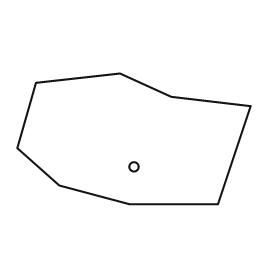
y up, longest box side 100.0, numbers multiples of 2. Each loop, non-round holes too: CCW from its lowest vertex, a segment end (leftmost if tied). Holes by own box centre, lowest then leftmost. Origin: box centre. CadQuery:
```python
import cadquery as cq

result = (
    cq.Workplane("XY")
    .moveTo(-2.0, -28.0)
    .lineTo(36.0, -28.0)
    .lineTo(50.0, 14.0)
    .lineTo(16.0, 18.0)
    .lineTo(-6.0, 28.0)
    .lineTo(-42.0, 24.0)
    .lineTo(-50.0, -4.0)
    .lineTo(-32.0, -20.0)
    .close()
    .moveTo(0.0, -12.0)
    .circle(2.0)
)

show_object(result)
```